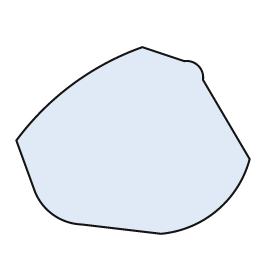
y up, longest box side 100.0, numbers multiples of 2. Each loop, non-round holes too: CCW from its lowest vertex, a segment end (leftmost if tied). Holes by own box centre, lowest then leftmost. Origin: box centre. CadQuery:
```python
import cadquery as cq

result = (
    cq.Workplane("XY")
    .moveTo(12.0, -40.0)
    .threePointArc((36.0, -30.0), (50.0, -8.0))
    .lineTo(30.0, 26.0)
    .threePointArc((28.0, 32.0), (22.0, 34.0))
    .lineTo(4.0, 40.0)
    .threePointArc((-26.0, 24.0), (-50.0, 0.0))
    .lineTo(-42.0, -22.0)
    .threePointArc((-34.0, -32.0), (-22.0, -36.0))
    .close()
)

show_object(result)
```